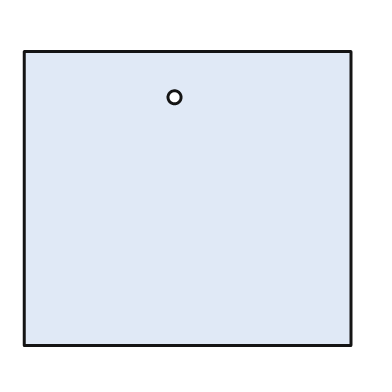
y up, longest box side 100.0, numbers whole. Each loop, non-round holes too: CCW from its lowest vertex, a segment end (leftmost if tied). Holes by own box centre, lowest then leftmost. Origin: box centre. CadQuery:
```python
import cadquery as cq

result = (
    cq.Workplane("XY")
    .moveTo(-50.0, -45.0)
    .lineTo(50.0, -45.0)
    .lineTo(50.0, 45.0)
    .lineTo(-50.0, 45.0)
    .close()
    .moveTo(-4.0, 31.0)
    .circle(2.0)
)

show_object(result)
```